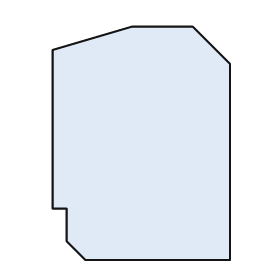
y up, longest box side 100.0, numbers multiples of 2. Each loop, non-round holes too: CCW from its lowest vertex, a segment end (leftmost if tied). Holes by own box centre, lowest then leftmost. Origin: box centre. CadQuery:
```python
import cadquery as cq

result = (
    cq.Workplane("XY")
    .moveTo(-24.0, -50.0)
    .lineTo(38.0, -50.0)
    .lineTo(38.0, 34.0)
    .lineTo(22.0, 50.0)
    .lineTo(-4.0, 50.0)
    .lineTo(-38.0, 40.0)
    .lineTo(-38.0, -28.0)
    .lineTo(-32.0, -28.0)
    .lineTo(-32.0, -42.0)
    .close()
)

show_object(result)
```